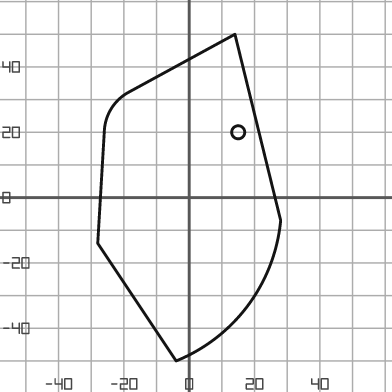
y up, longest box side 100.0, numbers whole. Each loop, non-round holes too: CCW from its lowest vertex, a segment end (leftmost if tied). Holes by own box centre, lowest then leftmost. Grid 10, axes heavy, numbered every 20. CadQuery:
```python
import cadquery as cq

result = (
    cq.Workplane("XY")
    .moveTo(-4.0, -50.0)
    .threePointArc((18.0, -33.0), (28.0, -7.0))
    .lineTo(14.0, 50.0)
    .lineTo(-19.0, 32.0)
    .threePointArc((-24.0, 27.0), (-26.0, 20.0))
    .lineTo(-28.0, -14.0)
    .close()
    .moveTo(15.0, 20.0)
    .circle(2.0)
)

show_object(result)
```